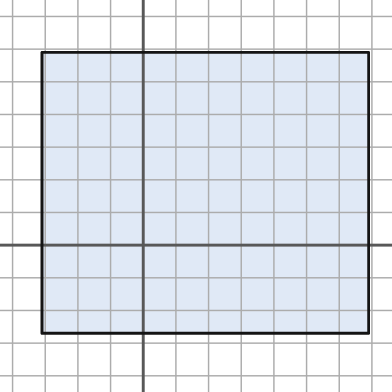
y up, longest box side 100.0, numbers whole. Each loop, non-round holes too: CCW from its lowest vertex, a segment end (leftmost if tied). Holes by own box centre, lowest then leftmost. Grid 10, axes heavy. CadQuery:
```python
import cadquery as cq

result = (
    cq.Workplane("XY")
    .moveTo(-31.0, -27.0)
    .lineTo(69.0, -27.0)
    .lineTo(69.0, 59.0)
    .lineTo(-31.0, 59.0)
    .close()
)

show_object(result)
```